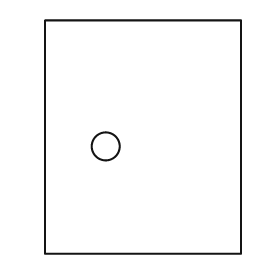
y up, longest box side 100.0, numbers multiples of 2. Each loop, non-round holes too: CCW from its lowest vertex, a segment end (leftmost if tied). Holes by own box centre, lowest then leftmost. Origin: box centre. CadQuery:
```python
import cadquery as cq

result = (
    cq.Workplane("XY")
    .moveTo(-42.0, -50.0)
    .lineTo(42.0, -50.0)
    .lineTo(42.0, 50.0)
    .lineTo(-42.0, 50.0)
    .close()
    .moveTo(-16.0, -4.0)
    .circle(6.0)
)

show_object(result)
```